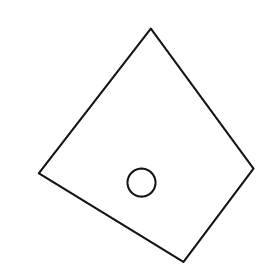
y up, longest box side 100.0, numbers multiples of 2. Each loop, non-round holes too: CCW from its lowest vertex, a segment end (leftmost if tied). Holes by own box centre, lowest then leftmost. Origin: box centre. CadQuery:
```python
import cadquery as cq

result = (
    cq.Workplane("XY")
    .moveTo(16.0, -50.0)
    .lineTo(46.0, -10.0)
    .lineTo(2.0, 50.0)
    .lineTo(-46.0, -12.0)
    .close()
    .moveTo(-2.0, -16.0)
    .circle(6.0)
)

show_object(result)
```